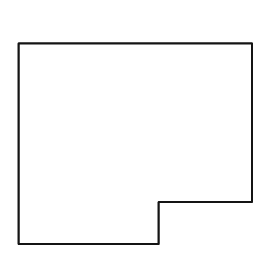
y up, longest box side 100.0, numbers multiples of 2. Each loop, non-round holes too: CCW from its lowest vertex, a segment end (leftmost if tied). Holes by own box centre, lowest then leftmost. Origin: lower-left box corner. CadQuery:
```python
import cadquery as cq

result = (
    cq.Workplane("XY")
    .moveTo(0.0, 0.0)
    .lineTo(60.0, 0.0)
    .lineTo(60.0, 18.0)
    .lineTo(100.0, 18.0)
    .lineTo(100.0, 86.0)
    .lineTo(0.0, 86.0)
    .close()
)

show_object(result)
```